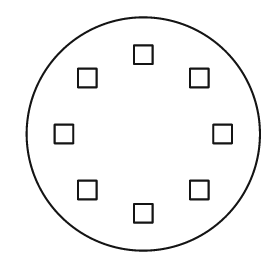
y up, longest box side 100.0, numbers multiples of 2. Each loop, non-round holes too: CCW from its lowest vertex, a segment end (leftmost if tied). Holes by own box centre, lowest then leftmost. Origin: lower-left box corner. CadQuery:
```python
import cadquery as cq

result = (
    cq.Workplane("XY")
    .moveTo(50.0, 50.0)
    .circle(50.0)
    .moveTo(46.0, 12.0)
    .lineTo(54.0, 12.0)
    .lineTo(54.0, 20.0)
    .lineTo(46.0, 20.0)
    .close()
    .moveTo(22.0, 22.0)
    .lineTo(30.0, 22.0)
    .lineTo(30.0, 30.0)
    .lineTo(22.0, 30.0)
    .close()
    .moveTo(70.0, 22.0)
    .lineTo(78.0, 22.0)
    .lineTo(78.0, 30.0)
    .lineTo(70.0, 30.0)
    .close()
    .moveTo(12.0, 46.0)
    .lineTo(20.0, 46.0)
    .lineTo(20.0, 54.0)
    .lineTo(12.0, 54.0)
    .close()
    .moveTo(80.0, 46.0)
    .lineTo(88.0, 46.0)
    .lineTo(88.0, 54.0)
    .lineTo(80.0, 54.0)
    .close()
    .moveTo(22.0, 70.0)
    .lineTo(30.0, 70.0)
    .lineTo(30.0, 78.0)
    .lineTo(22.0, 78.0)
    .close()
    .moveTo(70.0, 70.0)
    .lineTo(78.0, 70.0)
    .lineTo(78.0, 78.0)
    .lineTo(70.0, 78.0)
    .close()
    .moveTo(46.0, 80.0)
    .lineTo(54.0, 80.0)
    .lineTo(54.0, 88.0)
    .lineTo(46.0, 88.0)
    .close()
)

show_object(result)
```